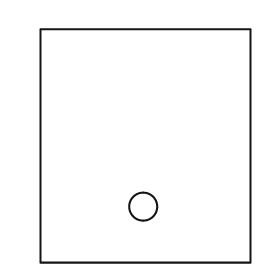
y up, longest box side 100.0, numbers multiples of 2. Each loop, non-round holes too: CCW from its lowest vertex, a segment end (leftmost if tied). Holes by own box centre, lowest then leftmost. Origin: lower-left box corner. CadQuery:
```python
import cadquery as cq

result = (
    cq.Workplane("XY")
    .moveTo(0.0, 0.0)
    .lineTo(90.0, 0.0)
    .lineTo(90.0, 100.0)
    .lineTo(0.0, 100.0)
    .close()
    .moveTo(44.0, 24.0)
    .circle(6.0)
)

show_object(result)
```